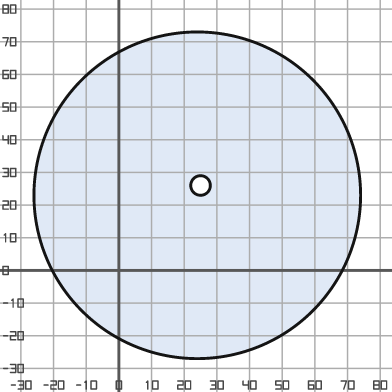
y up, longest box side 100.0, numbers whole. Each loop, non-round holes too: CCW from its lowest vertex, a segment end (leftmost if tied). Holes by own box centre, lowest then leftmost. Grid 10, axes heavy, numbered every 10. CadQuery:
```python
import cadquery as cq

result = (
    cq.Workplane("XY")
    .moveTo(24.0, 23.0)
    .circle(50.0)
    .moveTo(25.0, 26.0)
    .circle(3.0)
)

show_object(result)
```